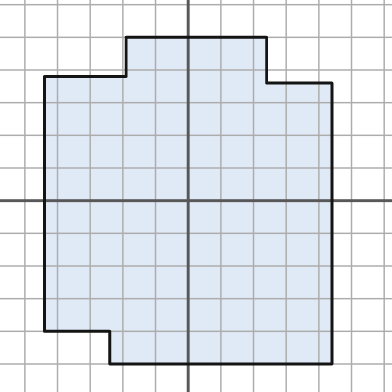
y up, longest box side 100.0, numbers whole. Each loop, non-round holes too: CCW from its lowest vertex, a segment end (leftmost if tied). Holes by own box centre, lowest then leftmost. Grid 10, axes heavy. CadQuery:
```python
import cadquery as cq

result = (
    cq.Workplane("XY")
    .moveTo(-24.0, -50.0)
    .lineTo(44.0, -50.0)
    .lineTo(44.0, 36.0)
    .lineTo(24.0, 36.0)
    .lineTo(24.0, 50.0)
    .lineTo(-19.0, 50.0)
    .lineTo(-19.0, 38.0)
    .lineTo(-44.0, 38.0)
    .lineTo(-44.0, -40.0)
    .lineTo(-24.0, -40.0)
    .close()
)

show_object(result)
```